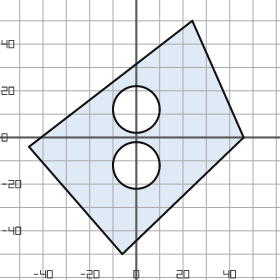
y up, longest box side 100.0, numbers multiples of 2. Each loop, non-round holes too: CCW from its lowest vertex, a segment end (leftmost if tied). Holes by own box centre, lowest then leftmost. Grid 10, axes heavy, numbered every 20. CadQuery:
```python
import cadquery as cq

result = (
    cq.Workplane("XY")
    .moveTo(-6.0, -50.0)
    .lineTo(46.0, 0.0)
    .lineTo(24.0, 50.0)
    .lineTo(-46.0, -4.0)
    .close()
    .moveTo(0.0, -12.0)
    .circle(10.0)
    .moveTo(0.0, 12.0)
    .circle(10.0)
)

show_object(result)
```